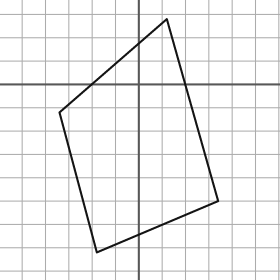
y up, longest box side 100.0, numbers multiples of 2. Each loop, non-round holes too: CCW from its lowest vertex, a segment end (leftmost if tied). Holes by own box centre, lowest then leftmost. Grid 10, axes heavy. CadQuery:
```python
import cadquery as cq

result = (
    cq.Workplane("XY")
    .moveTo(-18.0, -72.0)
    .lineTo(34.0, -50.0)
    .lineTo(12.0, 28.0)
    .lineTo(-34.0, -12.0)
    .close()
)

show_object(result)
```